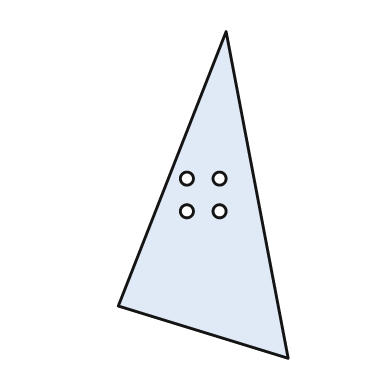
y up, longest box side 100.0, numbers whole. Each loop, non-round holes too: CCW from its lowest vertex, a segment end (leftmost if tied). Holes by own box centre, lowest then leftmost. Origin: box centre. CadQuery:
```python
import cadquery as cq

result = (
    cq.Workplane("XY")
    .moveTo(26.0, -50.0)
    .lineTo(7.0, 50.0)
    .lineTo(-26.0, -34.0)
    .close()
    .moveTo(-5.0, -5.0)
    .circle(2.0)
    .moveTo(5.0, -5.0)
    .circle(2.0)
    .moveTo(-5.0, 5.0)
    .circle(2.0)
    .moveTo(5.0, 5.0)
    .circle(2.0)
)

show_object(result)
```